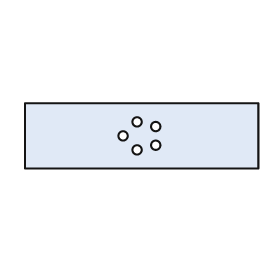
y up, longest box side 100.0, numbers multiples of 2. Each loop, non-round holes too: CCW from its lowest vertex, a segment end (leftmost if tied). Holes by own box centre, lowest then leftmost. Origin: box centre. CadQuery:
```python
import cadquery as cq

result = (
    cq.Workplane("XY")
    .moveTo(-50.0, -14.0)
    .lineTo(50.0, -14.0)
    .lineTo(50.0, 14.0)
    .lineTo(-50.0, 14.0)
    .close()
    .moveTo(-2.0, -6.0)
    .circle(2.0)
    .moveTo(6.0, -4.0)
    .circle(2.0)
    .moveTo(-8.0, 0.0)
    .circle(2.0)
    .moveTo(6.0, 4.0)
    .circle(2.0)
    .moveTo(-2.0, 6.0)
    .circle(2.0)
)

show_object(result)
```